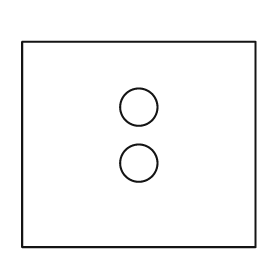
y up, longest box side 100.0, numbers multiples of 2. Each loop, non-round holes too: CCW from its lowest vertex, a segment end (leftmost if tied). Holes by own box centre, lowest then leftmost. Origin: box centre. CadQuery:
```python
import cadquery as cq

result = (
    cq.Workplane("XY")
    .moveTo(-50.0, -44.0)
    .lineTo(50.0, -44.0)
    .lineTo(50.0, 44.0)
    .lineTo(-50.0, 44.0)
    .close()
    .moveTo(0.0, -8.0)
    .circle(8.0)
    .moveTo(0.0, 16.0)
    .circle(8.0)
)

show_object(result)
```